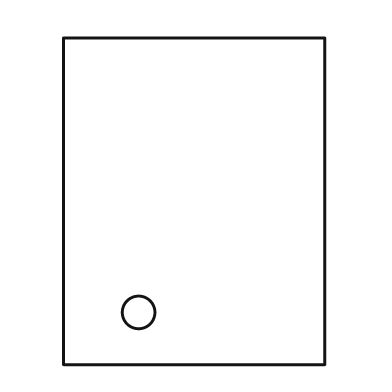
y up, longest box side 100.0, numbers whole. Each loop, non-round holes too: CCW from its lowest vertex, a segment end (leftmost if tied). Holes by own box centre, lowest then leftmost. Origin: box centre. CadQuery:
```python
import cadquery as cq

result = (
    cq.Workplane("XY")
    .moveTo(-40.0, -50.0)
    .lineTo(40.0, -50.0)
    .lineTo(40.0, 50.0)
    .lineTo(-40.0, 50.0)
    .close()
    .moveTo(-17.0, -34.0)
    .circle(5.0)
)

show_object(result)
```